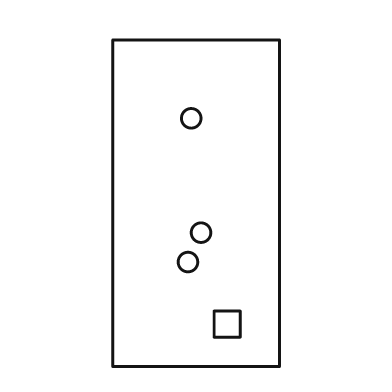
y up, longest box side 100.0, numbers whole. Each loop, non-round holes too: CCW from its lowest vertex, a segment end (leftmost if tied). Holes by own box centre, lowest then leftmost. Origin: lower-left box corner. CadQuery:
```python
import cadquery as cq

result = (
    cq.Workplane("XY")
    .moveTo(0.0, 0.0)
    .lineTo(51.0, 0.0)
    .lineTo(51.0, 100.0)
    .lineTo(0.0, 100.0)
    .close()
    .moveTo(31.0, 9.0)
    .lineTo(39.0, 9.0)
    .lineTo(39.0, 17.0)
    .lineTo(31.0, 17.0)
    .close()
    .moveTo(23.0, 32.0)
    .circle(3.0)
    .moveTo(27.0, 41.0)
    .circle(3.0)
    .moveTo(24.0, 76.0)
    .circle(3.0)
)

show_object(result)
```